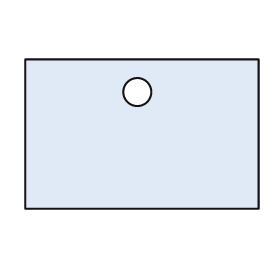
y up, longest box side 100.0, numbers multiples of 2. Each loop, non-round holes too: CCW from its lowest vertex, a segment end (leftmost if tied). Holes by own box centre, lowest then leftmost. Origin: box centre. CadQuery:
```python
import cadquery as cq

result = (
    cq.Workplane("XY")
    .moveTo(-50.0, -32.0)
    .lineTo(50.0, -32.0)
    .lineTo(50.0, 32.0)
    .lineTo(-50.0, 32.0)
    .close()
    .moveTo(-2.0, 18.0)
    .circle(6.0)
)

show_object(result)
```